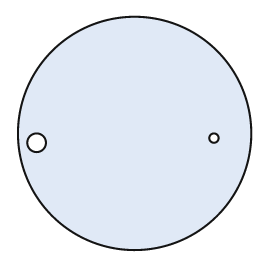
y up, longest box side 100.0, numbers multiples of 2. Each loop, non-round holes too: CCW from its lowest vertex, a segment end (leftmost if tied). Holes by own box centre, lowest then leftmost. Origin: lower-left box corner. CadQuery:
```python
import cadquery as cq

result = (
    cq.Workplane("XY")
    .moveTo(50.0, 50.0)
    .circle(50.0)
    .moveTo(8.0, 46.0)
    .circle(4.0)
    .moveTo(84.0, 48.0)
    .circle(2.0)
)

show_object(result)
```